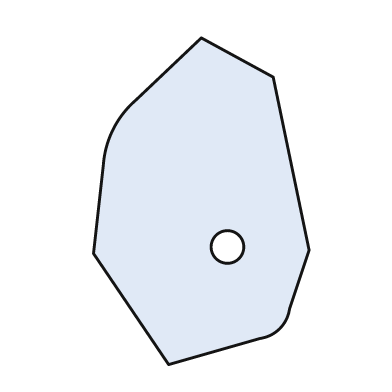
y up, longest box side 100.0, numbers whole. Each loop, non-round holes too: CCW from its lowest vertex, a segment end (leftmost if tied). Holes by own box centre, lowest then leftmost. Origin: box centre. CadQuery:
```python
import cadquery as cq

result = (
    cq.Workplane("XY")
    .moveTo(-10.0, -50.0)
    .lineTo(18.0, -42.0)
    .threePointArc((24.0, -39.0), (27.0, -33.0))
    .lineTo(33.0, -15.0)
    .lineTo(22.0, 38.0)
    .lineTo(0.0, 50.0)
    .lineTo(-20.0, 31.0)
    .threePointArc((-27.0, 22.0), (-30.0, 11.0))
    .lineTo(-33.0, -16.0)
    .close()
    .moveTo(8.0, -14.0)
    .circle(5.0)
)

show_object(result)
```